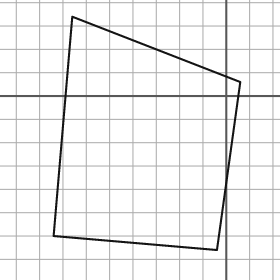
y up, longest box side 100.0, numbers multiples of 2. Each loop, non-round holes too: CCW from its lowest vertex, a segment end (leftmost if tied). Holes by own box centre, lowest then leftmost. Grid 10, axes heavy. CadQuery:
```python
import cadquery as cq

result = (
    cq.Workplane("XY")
    .moveTo(-4.0, -66.0)
    .lineTo(6.0, 6.0)
    .lineTo(-66.0, 34.0)
    .lineTo(-74.0, -60.0)
    .close()
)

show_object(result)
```